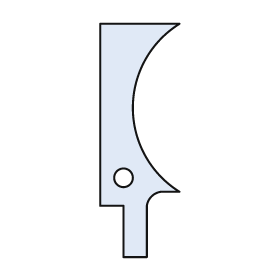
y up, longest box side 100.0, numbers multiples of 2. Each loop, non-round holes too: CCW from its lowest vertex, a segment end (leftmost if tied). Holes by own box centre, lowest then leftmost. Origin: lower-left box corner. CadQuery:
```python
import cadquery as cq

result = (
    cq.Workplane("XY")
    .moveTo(10.0, 0.0)
    .lineTo(20.0, 0.0)
    .lineTo(20.0, 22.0)
    .threePointArc((22.0, 26.0), (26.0, 28.0))
    .lineTo(34.0, 28.0)
    .threePointArc((14.0, 64.0), (34.0, 100.0))
    .lineTo(0.0, 100.0)
    .lineTo(0.0, 22.0)
    .lineTo(10.0, 22.0)
    .close()
    .moveTo(10.0, 34.0)
    .circle(4.0)
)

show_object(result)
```